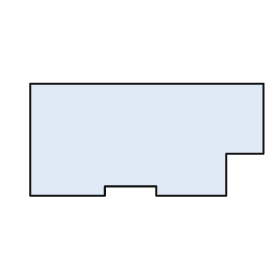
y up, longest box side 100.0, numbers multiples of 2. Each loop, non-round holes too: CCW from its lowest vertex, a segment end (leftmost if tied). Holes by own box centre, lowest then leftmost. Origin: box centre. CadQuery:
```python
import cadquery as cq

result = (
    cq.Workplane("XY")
    .moveTo(-50.0, -24.0)
    .lineTo(-18.0, -24.0)
    .lineTo(-18.0, -20.0)
    .lineTo(4.0, -20.0)
    .lineTo(4.0, -24.0)
    .lineTo(34.0, -24.0)
    .lineTo(34.0, -6.0)
    .lineTo(50.0, -6.0)
    .lineTo(50.0, 24.0)
    .lineTo(-50.0, 24.0)
    .close()
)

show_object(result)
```